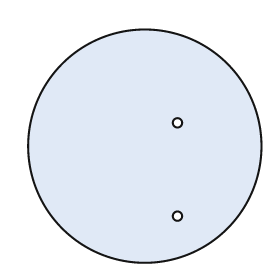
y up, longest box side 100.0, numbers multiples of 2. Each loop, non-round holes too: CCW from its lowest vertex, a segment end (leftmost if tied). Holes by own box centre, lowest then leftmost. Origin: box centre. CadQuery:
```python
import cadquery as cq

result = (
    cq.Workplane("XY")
    .moveTo(0.0, 0.0)
    .circle(50.0)
    .moveTo(14.0, -30.0)
    .circle(2.0)
    .moveTo(14.0, 10.0)
    .circle(2.0)
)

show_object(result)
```